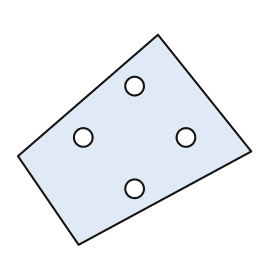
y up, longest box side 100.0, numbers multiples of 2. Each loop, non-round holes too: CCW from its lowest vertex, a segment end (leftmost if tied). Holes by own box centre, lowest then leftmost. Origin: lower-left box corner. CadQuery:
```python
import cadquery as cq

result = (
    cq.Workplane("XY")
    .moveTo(26.0, 0.0)
    .lineTo(100.0, 40.0)
    .lineTo(60.0, 90.0)
    .lineTo(0.0, 38.0)
    .close()
    .moveTo(50.0, 24.0)
    .circle(4.0)
    .moveTo(28.0, 46.0)
    .circle(4.0)
    .moveTo(72.0, 46.0)
    .circle(4.0)
    .moveTo(50.0, 68.0)
    .circle(4.0)
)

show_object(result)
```